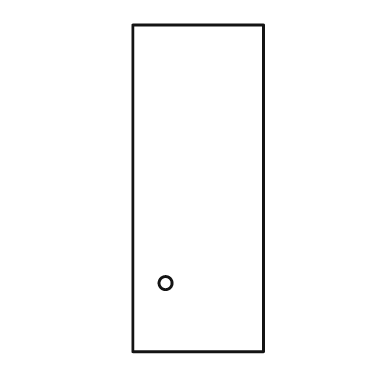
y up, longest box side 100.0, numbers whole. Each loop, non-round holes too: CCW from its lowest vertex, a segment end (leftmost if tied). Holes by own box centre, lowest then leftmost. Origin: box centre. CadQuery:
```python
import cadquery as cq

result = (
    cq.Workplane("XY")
    .moveTo(-20.0, -50.0)
    .lineTo(20.0, -50.0)
    .lineTo(20.0, 50.0)
    .lineTo(-20.0, 50.0)
    .close()
    .moveTo(-10.0, -29.0)
    .circle(2.0)
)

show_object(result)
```